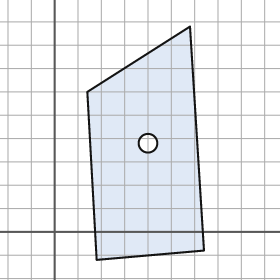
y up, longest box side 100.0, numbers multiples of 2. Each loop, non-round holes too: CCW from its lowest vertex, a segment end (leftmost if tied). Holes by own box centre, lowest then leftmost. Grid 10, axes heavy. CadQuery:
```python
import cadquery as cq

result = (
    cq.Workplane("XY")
    .moveTo(18.0, -12.0)
    .lineTo(64.0, -8.0)
    .lineTo(58.0, 88.0)
    .lineTo(14.0, 60.0)
    .close()
    .moveTo(40.0, 38.0)
    .circle(4.0)
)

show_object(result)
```